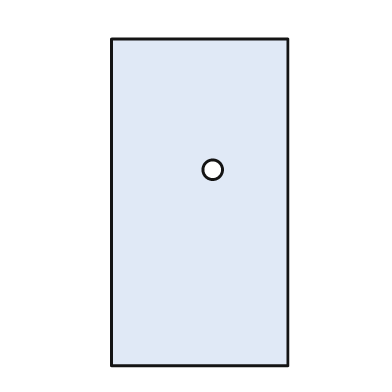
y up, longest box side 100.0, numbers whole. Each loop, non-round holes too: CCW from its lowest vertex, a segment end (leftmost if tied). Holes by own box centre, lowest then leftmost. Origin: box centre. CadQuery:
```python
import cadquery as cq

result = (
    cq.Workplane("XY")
    .moveTo(-27.0, -50.0)
    .lineTo(27.0, -50.0)
    .lineTo(27.0, 50.0)
    .lineTo(-27.0, 50.0)
    .close()
    .moveTo(4.0, 10.0)
    .circle(3.0)
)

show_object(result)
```